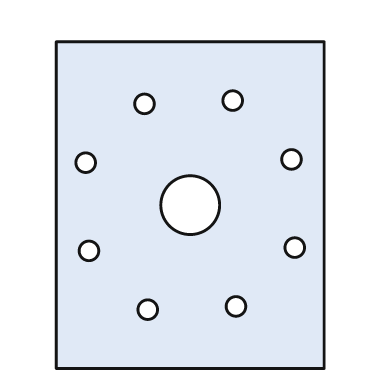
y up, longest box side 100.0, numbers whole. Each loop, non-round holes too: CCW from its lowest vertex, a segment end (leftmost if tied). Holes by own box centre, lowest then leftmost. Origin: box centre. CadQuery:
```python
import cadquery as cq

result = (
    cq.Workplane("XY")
    .moveTo(-41.0, -50.0)
    .lineTo(41.0, -50.0)
    .lineTo(41.0, 50.0)
    .lineTo(-41.0, 50.0)
    .close()
    .moveTo(-13.0, -32.0)
    .circle(3.0)
    .moveTo(14.0, -31.0)
    .circle(3.0)
    .moveTo(-31.0, -14.0)
    .circle(3.0)
    .moveTo(32.0, -13.0)
    .circle(3.0)
    .moveTo(0.0, 0.0)
    .circle(9.0)
    .moveTo(-32.0, 13.0)
    .circle(3.0)
    .moveTo(31.0, 14.0)
    .circle(3.0)
    .moveTo(-14.0, 31.0)
    .circle(3.0)
    .moveTo(13.0, 32.0)
    .circle(3.0)
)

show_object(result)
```